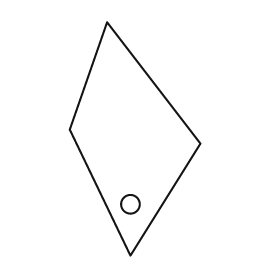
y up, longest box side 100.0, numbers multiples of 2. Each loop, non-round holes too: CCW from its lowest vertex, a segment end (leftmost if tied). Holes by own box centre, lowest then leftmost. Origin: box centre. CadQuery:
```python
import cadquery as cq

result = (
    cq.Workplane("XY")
    .moveTo(-2.0, -50.0)
    .lineTo(28.0, -2.0)
    .lineTo(-12.0, 50.0)
    .lineTo(-28.0, 4.0)
    .close()
    .moveTo(-2.0, -28.0)
    .circle(4.0)
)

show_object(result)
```